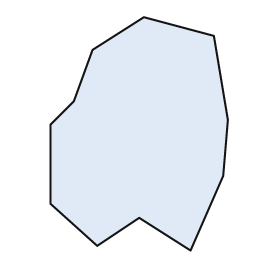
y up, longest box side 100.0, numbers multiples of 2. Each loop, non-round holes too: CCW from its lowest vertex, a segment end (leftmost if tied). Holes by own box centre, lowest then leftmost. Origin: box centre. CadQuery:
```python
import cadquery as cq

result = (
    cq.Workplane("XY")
    .moveTo(22.0, -50.0)
    .lineTo(36.0, -18.0)
    .lineTo(38.0, 6.0)
    .lineTo(32.0, 42.0)
    .lineTo(2.0, 50.0)
    .lineTo(-20.0, 36.0)
    .lineTo(-28.0, 14.0)
    .lineTo(-38.0, 4.0)
    .lineTo(-38.0, -30.0)
    .lineTo(-18.0, -48.0)
    .lineTo(0.0, -36.0)
    .close()
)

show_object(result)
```